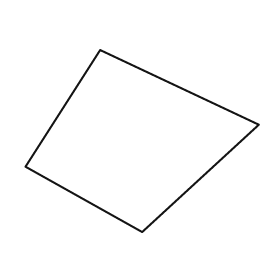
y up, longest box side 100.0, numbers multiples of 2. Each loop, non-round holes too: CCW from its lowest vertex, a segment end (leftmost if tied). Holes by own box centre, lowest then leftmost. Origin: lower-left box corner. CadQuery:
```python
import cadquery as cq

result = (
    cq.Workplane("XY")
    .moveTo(50.0, 0.0)
    .lineTo(100.0, 46.0)
    .lineTo(32.0, 78.0)
    .lineTo(0.0, 28.0)
    .close()
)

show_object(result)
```